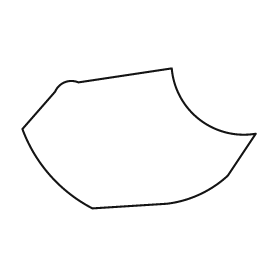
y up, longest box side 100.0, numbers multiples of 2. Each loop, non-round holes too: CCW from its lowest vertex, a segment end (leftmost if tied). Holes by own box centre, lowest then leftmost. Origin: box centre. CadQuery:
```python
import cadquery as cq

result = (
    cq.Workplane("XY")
    .moveTo(-20.0, -30.0)
    .lineTo(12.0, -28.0)
    .threePointArc((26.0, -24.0), (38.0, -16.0))
    .lineTo(50.0, 2.0)
    .threePointArc((26.0, 8.0), (14.0, 30.0))
    .lineTo(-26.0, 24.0)
    .threePointArc((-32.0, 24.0), (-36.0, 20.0))
    .lineTo(-50.0, 4.0)
    .threePointArc((-38.0, -16.0), (-20.0, -30.0))
    .close()
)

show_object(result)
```